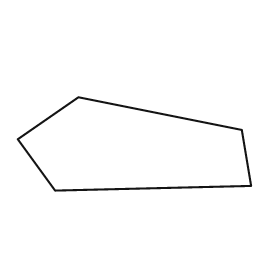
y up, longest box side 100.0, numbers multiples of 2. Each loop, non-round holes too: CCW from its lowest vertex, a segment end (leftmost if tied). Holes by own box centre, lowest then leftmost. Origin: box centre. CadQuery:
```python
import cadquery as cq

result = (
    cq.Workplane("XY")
    .moveTo(-34.0, -20.0)
    .lineTo(50.0, -18.0)
    .lineTo(46.0, 6.0)
    .lineTo(-24.0, 20.0)
    .lineTo(-50.0, 2.0)
    .close()
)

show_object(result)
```